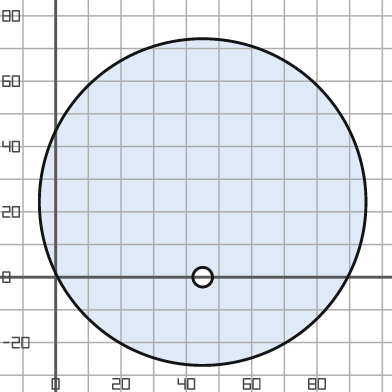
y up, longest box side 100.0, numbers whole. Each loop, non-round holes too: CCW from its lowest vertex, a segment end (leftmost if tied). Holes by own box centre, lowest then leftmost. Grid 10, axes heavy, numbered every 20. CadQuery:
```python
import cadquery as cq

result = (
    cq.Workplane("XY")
    .moveTo(45.0, 23.0)
    .circle(50.0)
    .moveTo(45.0, 0.0)
    .circle(3.0)
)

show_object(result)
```